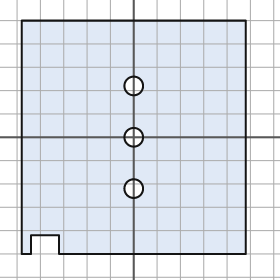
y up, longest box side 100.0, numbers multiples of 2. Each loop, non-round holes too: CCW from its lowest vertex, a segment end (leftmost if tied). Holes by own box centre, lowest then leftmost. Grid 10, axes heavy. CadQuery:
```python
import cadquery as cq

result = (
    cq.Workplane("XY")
    .moveTo(-48.0, -50.0)
    .lineTo(-44.0, -50.0)
    .lineTo(-44.0, -42.0)
    .lineTo(-32.0, -42.0)
    .lineTo(-32.0, -50.0)
    .lineTo(48.0, -50.0)
    .lineTo(48.0, 50.0)
    .lineTo(-48.0, 50.0)
    .close()
    .moveTo(0.0, -22.0)
    .circle(4.0)
    .moveTo(0.0, 0.0)
    .circle(4.0)
    .moveTo(0.0, 22.0)
    .circle(4.0)
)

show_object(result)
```